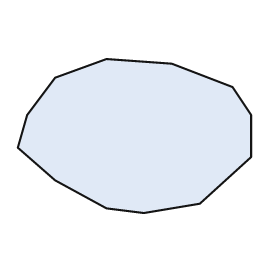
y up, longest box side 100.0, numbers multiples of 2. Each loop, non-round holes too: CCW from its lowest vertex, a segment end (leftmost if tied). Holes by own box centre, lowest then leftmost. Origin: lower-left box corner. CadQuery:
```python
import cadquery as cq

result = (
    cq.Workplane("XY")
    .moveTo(54.0, 0.0)
    .lineTo(78.0, 4.0)
    .lineTo(100.0, 24.0)
    .lineTo(100.0, 42.0)
    .lineTo(92.0, 54.0)
    .lineTo(66.0, 64.0)
    .lineTo(38.0, 66.0)
    .lineTo(16.0, 58.0)
    .lineTo(4.0, 42.0)
    .lineTo(0.0, 28.0)
    .lineTo(16.0, 14.0)
    .lineTo(38.0, 2.0)
    .close()
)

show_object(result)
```